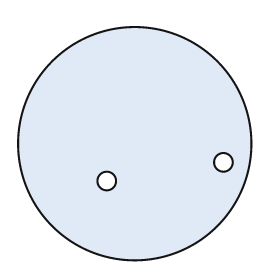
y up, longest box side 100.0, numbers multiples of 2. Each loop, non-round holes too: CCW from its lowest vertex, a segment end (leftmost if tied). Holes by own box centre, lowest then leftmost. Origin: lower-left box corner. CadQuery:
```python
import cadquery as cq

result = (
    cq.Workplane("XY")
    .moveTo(50.0, 50.0)
    .circle(50.0)
    .moveTo(38.0, 34.0)
    .circle(4.0)
    .moveTo(88.0, 42.0)
    .circle(4.0)
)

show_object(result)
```